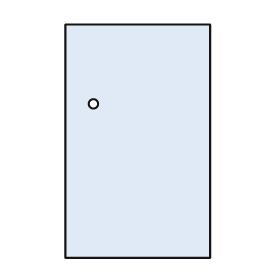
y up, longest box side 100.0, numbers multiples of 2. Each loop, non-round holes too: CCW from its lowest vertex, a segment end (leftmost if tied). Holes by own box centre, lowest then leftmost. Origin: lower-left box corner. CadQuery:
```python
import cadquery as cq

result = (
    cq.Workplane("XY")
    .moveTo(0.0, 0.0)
    .lineTo(62.0, 0.0)
    .lineTo(62.0, 100.0)
    .lineTo(0.0, 100.0)
    .close()
    .moveTo(12.0, 66.0)
    .circle(2.0)
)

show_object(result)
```